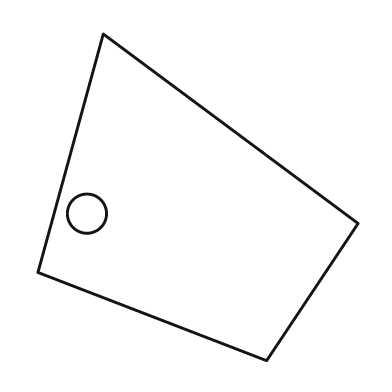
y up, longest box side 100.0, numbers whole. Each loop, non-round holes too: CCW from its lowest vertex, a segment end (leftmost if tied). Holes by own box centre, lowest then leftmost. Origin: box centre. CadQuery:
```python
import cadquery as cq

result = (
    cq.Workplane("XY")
    .moveTo(21.0, -50.0)
    .lineTo(49.0, -8.0)
    .lineTo(-29.0, 50.0)
    .lineTo(-49.0, -23.0)
    .close()
    .moveTo(-34.0, -5.0)
    .circle(6.0)
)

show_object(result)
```